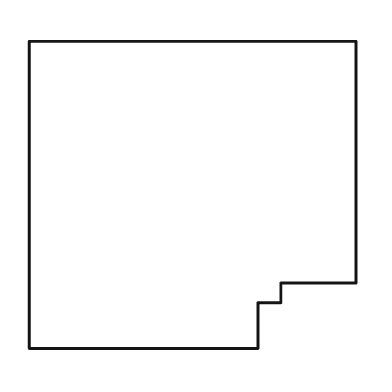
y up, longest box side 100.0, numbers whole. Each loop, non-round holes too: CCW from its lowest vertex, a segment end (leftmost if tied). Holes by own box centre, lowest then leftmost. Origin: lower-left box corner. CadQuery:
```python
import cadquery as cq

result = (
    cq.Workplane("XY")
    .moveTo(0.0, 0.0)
    .lineTo(70.0, 0.0)
    .lineTo(70.0, 14.0)
    .lineTo(77.0, 14.0)
    .lineTo(77.0, 20.0)
    .lineTo(100.0, 20.0)
    .lineTo(100.0, 94.0)
    .lineTo(0.0, 94.0)
    .close()
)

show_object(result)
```